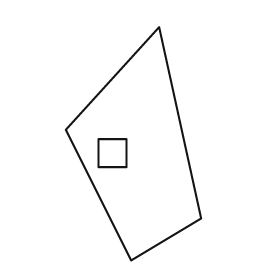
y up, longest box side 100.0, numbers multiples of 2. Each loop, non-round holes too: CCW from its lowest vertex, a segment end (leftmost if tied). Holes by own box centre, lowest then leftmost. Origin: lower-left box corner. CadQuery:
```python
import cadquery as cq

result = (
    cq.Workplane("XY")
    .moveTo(28.0, 0.0)
    .lineTo(58.0, 18.0)
    .lineTo(40.0, 100.0)
    .lineTo(0.0, 56.0)
    .close()
    .moveTo(14.0, 40.0)
    .lineTo(26.0, 40.0)
    .lineTo(26.0, 52.0)
    .lineTo(14.0, 52.0)
    .close()
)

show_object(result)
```